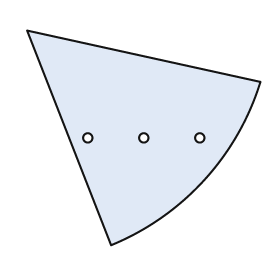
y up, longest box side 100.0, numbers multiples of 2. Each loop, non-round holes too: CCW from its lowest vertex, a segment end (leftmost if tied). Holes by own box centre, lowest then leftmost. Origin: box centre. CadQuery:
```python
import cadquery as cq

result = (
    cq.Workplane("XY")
    .moveTo(-14.0, -46.0)
    .threePointArc((26.0, -18.0), (50.0, 24.0))
    .lineTo(-50.0, 46.0)
    .close()
    .moveTo(-24.0, 0.0)
    .circle(2.0)
    .moveTo(0.0, 0.0)
    .circle(2.0)
    .moveTo(24.0, 0.0)
    .circle(2.0)
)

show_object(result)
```